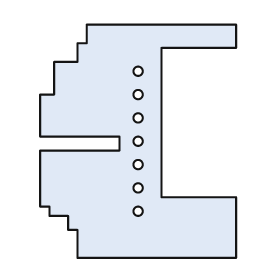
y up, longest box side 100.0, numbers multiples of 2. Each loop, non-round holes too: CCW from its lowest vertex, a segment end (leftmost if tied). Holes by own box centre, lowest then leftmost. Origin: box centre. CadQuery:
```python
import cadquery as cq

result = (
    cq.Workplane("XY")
    .moveTo(-26.0, -50.0)
    .lineTo(42.0, -50.0)
    .lineTo(42.0, -24.0)
    .lineTo(10.0, -24.0)
    .lineTo(10.0, 40.0)
    .lineTo(42.0, 40.0)
    .lineTo(42.0, 50.0)
    .lineTo(-22.0, 50.0)
    .lineTo(-22.0, 42.0)
    .lineTo(-26.0, 42.0)
    .lineTo(-26.0, 34.0)
    .lineTo(-36.0, 34.0)
    .lineTo(-36.0, 20.0)
    .lineTo(-42.0, 20.0)
    .lineTo(-42.0, 2.0)
    .lineTo(-8.0, 2.0)
    .lineTo(-8.0, -4.0)
    .lineTo(-42.0, -4.0)
    .lineTo(-42.0, -28.0)
    .lineTo(-38.0, -28.0)
    .lineTo(-38.0, -32.0)
    .lineTo(-30.0, -32.0)
    .lineTo(-30.0, -38.0)
    .lineTo(-26.0, -38.0)
    .close()
    .moveTo(0.0, -30.0)
    .circle(2.0)
    .moveTo(0.0, -20.0)
    .circle(2.0)
    .moveTo(0.0, -10.0)
    .circle(2.0)
    .moveTo(0.0, 0.0)
    .circle(2.0)
    .moveTo(0.0, 10.0)
    .circle(2.0)
    .moveTo(0.0, 20.0)
    .circle(2.0)
    .moveTo(0.0, 30.0)
    .circle(2.0)
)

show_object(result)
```